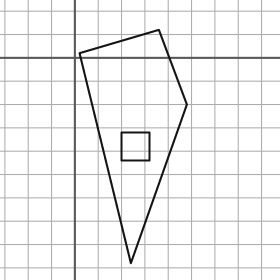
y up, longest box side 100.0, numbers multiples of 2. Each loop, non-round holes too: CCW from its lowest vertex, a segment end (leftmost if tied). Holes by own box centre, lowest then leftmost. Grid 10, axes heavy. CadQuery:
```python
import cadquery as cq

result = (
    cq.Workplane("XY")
    .moveTo(24.0, -88.0)
    .lineTo(48.0, -20.0)
    .lineTo(36.0, 12.0)
    .lineTo(2.0, 2.0)
    .close()
    .moveTo(20.0, -44.0)
    .lineTo(32.0, -44.0)
    .lineTo(32.0, -32.0)
    .lineTo(20.0, -32.0)
    .close()
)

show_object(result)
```